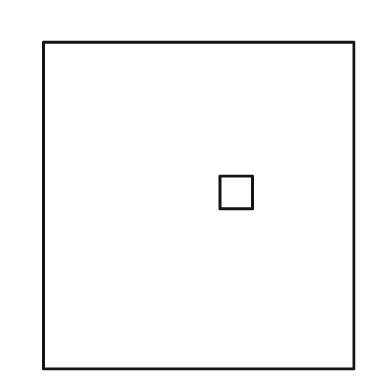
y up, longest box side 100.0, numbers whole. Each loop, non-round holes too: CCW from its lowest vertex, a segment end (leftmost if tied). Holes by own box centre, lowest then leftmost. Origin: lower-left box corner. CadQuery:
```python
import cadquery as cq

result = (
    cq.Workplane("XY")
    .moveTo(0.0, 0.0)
    .lineTo(95.0, 0.0)
    .lineTo(95.0, 100.0)
    .lineTo(0.0, 100.0)
    .close()
    .moveTo(54.0, 49.0)
    .lineTo(64.0, 49.0)
    .lineTo(64.0, 59.0)
    .lineTo(54.0, 59.0)
    .close()
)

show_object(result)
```